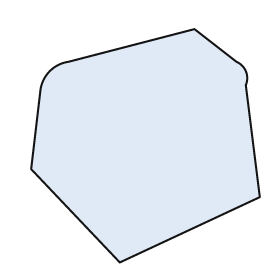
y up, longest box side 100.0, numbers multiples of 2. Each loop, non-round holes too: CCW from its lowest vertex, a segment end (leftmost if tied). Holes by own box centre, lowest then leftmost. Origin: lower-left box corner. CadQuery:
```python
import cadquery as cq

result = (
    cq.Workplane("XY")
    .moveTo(38.0, 0.0)
    .lineTo(98.0, 28.0)
    .lineTo(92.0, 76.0)
    .threePointArc((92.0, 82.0), (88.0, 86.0))
    .lineTo(70.0, 100.0)
    .lineTo(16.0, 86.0)
    .threePointArc((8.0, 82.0), (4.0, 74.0))
    .lineTo(0.0, 40.0)
    .close()
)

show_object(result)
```